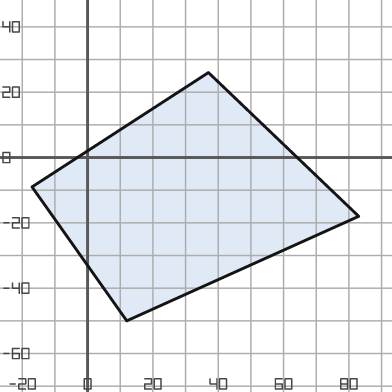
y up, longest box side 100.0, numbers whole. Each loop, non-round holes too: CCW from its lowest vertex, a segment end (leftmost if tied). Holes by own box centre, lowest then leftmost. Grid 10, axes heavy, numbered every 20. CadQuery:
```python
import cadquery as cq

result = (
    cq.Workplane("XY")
    .moveTo(12.0, -50.0)
    .lineTo(83.0, -18.0)
    .lineTo(37.0, 26.0)
    .lineTo(-17.0, -9.0)
    .close()
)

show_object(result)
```